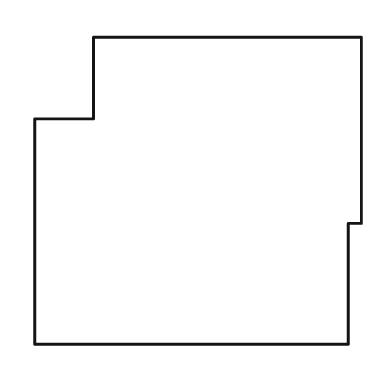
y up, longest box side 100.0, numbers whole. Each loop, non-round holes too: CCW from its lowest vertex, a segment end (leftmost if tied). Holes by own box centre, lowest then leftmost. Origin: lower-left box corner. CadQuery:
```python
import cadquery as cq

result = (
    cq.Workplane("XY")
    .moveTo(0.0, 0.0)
    .lineTo(96.0, 0.0)
    .lineTo(96.0, 37.0)
    .lineTo(100.0, 37.0)
    .lineTo(100.0, 94.0)
    .lineTo(18.0, 94.0)
    .lineTo(18.0, 69.0)
    .lineTo(0.0, 69.0)
    .close()
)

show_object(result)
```